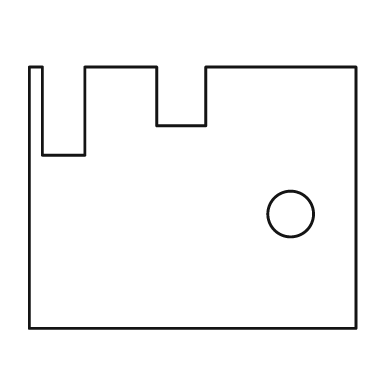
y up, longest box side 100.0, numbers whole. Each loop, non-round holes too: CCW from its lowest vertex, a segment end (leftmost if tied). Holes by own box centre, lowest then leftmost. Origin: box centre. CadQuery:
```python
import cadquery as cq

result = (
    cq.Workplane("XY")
    .moveTo(-50.0, -40.0)
    .lineTo(50.0, -40.0)
    .lineTo(50.0, 40.0)
    .lineTo(4.0, 40.0)
    .lineTo(4.0, 22.0)
    .lineTo(-11.0, 22.0)
    .lineTo(-11.0, 40.0)
    .lineTo(-33.0, 40.0)
    .lineTo(-33.0, 13.0)
    .lineTo(-46.0, 13.0)
    .lineTo(-46.0, 40.0)
    .lineTo(-50.0, 40.0)
    .close()
    .moveTo(30.0, -5.0)
    .circle(7.0)
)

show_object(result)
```